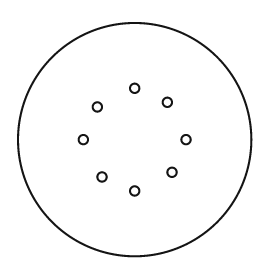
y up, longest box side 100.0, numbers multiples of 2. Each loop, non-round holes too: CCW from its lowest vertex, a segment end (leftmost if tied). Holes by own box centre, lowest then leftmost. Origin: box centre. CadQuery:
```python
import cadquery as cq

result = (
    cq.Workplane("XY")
    .moveTo(0.0, 0.0)
    .circle(50.0)
    .moveTo(0.0, -22.0)
    .circle(2.0)
    .moveTo(-14.0, -16.0)
    .circle(2.0)
    .moveTo(16.0, -14.0)
    .circle(2.0)
    .moveTo(-22.0, 0.0)
    .circle(2.0)
    .moveTo(22.0, 0.0)
    .circle(2.0)
    .moveTo(-16.0, 14.0)
    .circle(2.0)
    .moveTo(14.0, 16.0)
    .circle(2.0)
    .moveTo(0.0, 22.0)
    .circle(2.0)
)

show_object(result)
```